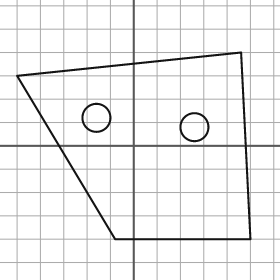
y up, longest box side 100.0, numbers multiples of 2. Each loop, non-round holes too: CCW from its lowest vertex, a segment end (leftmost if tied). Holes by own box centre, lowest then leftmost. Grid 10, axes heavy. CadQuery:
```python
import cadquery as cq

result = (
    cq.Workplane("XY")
    .moveTo(-8.0, -40.0)
    .lineTo(50.0, -40.0)
    .lineTo(46.0, 40.0)
    .lineTo(-50.0, 30.0)
    .close()
    .moveTo(26.0, 8.0)
    .circle(6.0)
    .moveTo(-16.0, 12.0)
    .circle(6.0)
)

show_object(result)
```